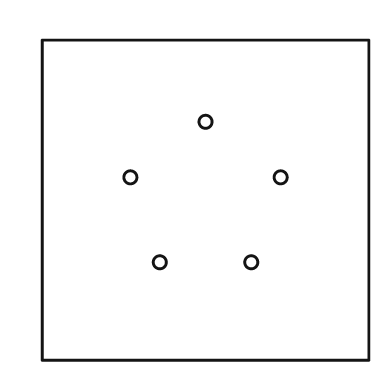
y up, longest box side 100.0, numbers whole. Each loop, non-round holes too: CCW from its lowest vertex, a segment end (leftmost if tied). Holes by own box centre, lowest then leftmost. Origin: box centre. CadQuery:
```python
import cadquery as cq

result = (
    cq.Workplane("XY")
    .moveTo(-50.0, -49.0)
    .lineTo(50.0, -49.0)
    .lineTo(50.0, 49.0)
    .lineTo(-50.0, 49.0)
    .close()
    .moveTo(-14.0, -19.0)
    .circle(2.0)
    .moveTo(14.0, -19.0)
    .circle(2.0)
    .moveTo(-23.0, 7.0)
    .circle(2.0)
    .moveTo(23.0, 7.0)
    .circle(2.0)
    .moveTo(0.0, 24.0)
    .circle(2.0)
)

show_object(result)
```